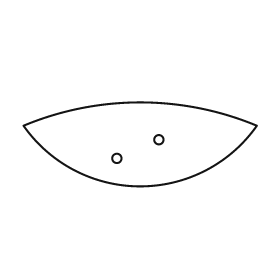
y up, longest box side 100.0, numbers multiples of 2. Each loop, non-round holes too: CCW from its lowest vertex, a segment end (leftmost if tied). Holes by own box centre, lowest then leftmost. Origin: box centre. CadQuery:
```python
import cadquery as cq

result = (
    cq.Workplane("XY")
    .moveTo(-50.0, 8.0)
    .threePointArc((0.0, -18.0), (50.0, 8.0))
    .threePointArc((0.0, 18.0), (-50.0, 8.0))
    .close()
    .moveTo(-10.0, -6.0)
    .circle(2.0)
    .moveTo(8.0, 2.0)
    .circle(2.0)
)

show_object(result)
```